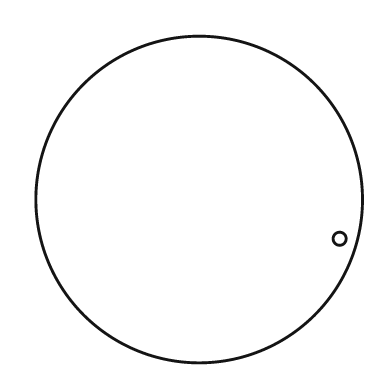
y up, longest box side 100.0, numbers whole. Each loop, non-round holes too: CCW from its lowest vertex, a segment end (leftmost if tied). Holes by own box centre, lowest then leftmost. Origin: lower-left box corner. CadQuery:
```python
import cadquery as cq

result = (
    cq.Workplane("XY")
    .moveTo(50.0, 50.0)
    .circle(50.0)
    .moveTo(93.0, 38.0)
    .circle(2.0)
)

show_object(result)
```